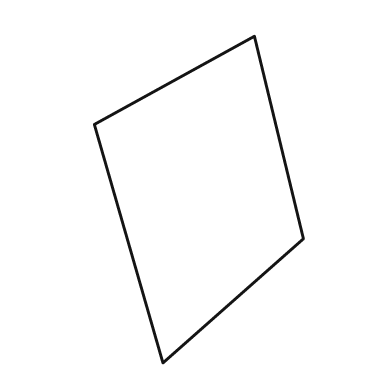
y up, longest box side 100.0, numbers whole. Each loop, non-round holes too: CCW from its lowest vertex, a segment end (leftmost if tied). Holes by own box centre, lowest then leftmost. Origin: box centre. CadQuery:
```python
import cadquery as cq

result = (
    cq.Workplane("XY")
    .moveTo(-11.0, -50.0)
    .lineTo(32.0, -12.0)
    .lineTo(17.0, 50.0)
    .lineTo(-32.0, 23.0)
    .close()
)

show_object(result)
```